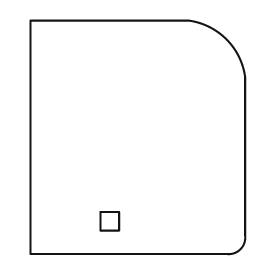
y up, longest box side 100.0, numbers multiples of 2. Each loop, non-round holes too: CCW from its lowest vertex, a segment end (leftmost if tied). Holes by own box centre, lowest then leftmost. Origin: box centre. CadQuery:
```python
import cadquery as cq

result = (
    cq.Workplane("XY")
    .moveTo(-46.0, -50.0)
    .lineTo(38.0, -50.0)
    .threePointArc((44.0, -48.0), (46.0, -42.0))
    .lineTo(46.0, 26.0)
    .threePointArc((38.0, 42.0), (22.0, 50.0))
    .lineTo(-46.0, 50.0)
    .close()
    .moveTo(-16.0, -40.0)
    .lineTo(-8.0, -40.0)
    .lineTo(-8.0, -32.0)
    .lineTo(-16.0, -32.0)
    .close()
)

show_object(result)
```